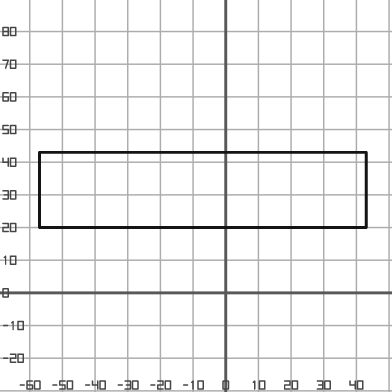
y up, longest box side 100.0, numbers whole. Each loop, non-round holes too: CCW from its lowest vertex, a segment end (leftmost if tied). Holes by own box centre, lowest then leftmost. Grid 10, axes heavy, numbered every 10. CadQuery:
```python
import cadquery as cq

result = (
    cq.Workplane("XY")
    .moveTo(-57.0, 20.0)
    .lineTo(43.0, 20.0)
    .lineTo(43.0, 43.0)
    .lineTo(-57.0, 43.0)
    .close()
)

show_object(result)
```